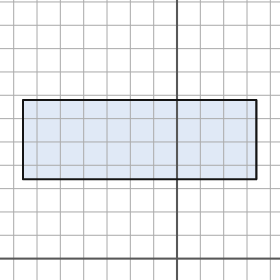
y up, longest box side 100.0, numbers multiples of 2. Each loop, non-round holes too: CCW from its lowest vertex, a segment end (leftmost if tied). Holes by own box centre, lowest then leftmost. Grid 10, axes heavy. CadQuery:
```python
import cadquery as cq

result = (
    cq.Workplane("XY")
    .moveTo(-66.0, 34.0)
    .lineTo(34.0, 34.0)
    .lineTo(34.0, 68.0)
    .lineTo(-66.0, 68.0)
    .close()
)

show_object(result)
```